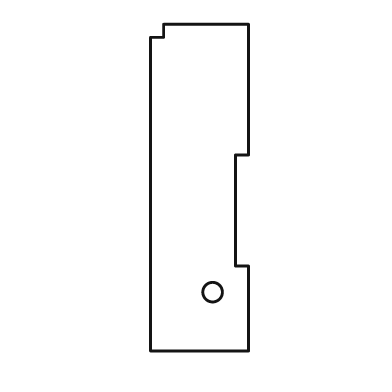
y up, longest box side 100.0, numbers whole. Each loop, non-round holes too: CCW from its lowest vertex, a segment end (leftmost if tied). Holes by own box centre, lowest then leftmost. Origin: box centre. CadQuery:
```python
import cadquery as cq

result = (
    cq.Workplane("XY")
    .moveTo(-15.0, -50.0)
    .lineTo(15.0, -50.0)
    .lineTo(15.0, -24.0)
    .lineTo(11.0, -24.0)
    .lineTo(11.0, 10.0)
    .lineTo(15.0, 10.0)
    .lineTo(15.0, 50.0)
    .lineTo(-11.0, 50.0)
    .lineTo(-11.0, 46.0)
    .lineTo(-15.0, 46.0)
    .close()
    .moveTo(4.0, -32.0)
    .circle(3.0)
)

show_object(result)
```